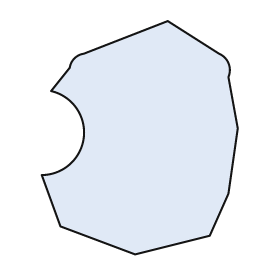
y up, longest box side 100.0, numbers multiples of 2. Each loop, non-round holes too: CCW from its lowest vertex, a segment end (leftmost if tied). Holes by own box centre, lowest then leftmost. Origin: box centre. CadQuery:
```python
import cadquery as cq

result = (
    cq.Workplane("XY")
    .moveTo(-2.0, -50.0)
    .lineTo(30.0, -42.0)
    .lineTo(38.0, -24.0)
    .lineTo(42.0, 4.0)
    .lineTo(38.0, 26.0)
    .threePointArc((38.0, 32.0), (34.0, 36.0))
    .lineTo(12.0, 50.0)
    .lineTo(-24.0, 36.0)
    .threePointArc((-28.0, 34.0), (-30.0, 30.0))
    .lineTo(-38.0, 20.0)
    .threePointArc((-24.0, 0.0), (-42.0, -16.0))
    .lineTo(-34.0, -38.0)
    .close()
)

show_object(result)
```